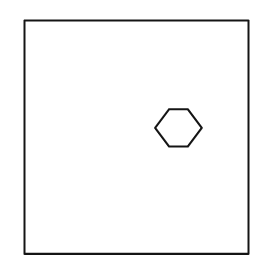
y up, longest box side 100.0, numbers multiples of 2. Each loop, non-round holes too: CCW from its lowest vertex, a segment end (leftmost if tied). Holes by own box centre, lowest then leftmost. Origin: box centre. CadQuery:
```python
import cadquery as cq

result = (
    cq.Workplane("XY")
    .moveTo(-48.0, -50.0)
    .lineTo(48.0, -50.0)
    .lineTo(48.0, 50.0)
    .lineTo(-48.0, 50.0)
    .close()
    .moveTo(14.0, -4.0)
    .lineTo(22.0, -4.0)
    .lineTo(28.0, 4.0)
    .lineTo(22.0, 12.0)
    .lineTo(14.0, 12.0)
    .lineTo(8.0, 4.0)
    .close()
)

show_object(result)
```